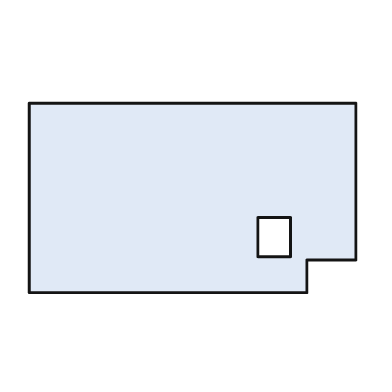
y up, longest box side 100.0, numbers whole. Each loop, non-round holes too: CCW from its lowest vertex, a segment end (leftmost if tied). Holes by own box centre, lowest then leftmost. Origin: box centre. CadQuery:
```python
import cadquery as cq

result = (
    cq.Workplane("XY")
    .moveTo(-50.0, -29.0)
    .lineTo(35.0, -29.0)
    .lineTo(35.0, -19.0)
    .lineTo(50.0, -19.0)
    .lineTo(50.0, 29.0)
    .lineTo(-50.0, 29.0)
    .close()
    .moveTo(20.0, -18.0)
    .lineTo(30.0, -18.0)
    .lineTo(30.0, -6.0)
    .lineTo(20.0, -6.0)
    .close()
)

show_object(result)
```